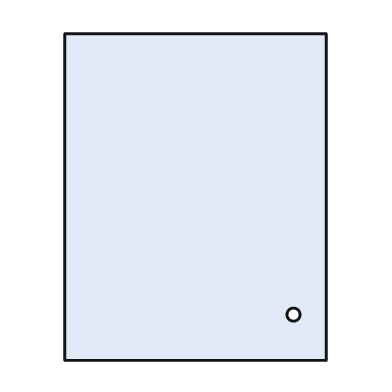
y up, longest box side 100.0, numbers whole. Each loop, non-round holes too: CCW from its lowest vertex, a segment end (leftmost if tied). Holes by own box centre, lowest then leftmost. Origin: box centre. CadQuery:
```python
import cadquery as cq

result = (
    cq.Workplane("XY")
    .moveTo(-40.0, -50.0)
    .lineTo(40.0, -50.0)
    .lineTo(40.0, 50.0)
    .lineTo(-40.0, 50.0)
    .close()
    .moveTo(30.0, -36.0)
    .circle(2.0)
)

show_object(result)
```